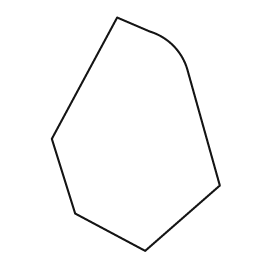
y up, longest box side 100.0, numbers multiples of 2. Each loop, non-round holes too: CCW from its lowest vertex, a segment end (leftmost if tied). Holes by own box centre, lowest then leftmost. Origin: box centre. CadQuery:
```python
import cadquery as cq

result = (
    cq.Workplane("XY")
    .moveTo(4.0, -50.0)
    .lineTo(36.0, -22.0)
    .lineTo(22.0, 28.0)
    .threePointArc((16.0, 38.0), (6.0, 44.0))
    .lineTo(-8.0, 50.0)
    .lineTo(-36.0, -2.0)
    .lineTo(-26.0, -34.0)
    .close()
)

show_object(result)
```